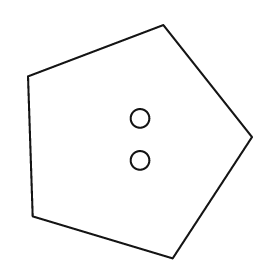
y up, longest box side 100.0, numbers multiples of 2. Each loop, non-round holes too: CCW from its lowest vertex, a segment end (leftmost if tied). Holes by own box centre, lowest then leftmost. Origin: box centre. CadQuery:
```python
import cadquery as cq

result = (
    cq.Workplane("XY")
    .moveTo(14.0, -50.0)
    .lineTo(48.0, 2.0)
    .lineTo(10.0, 50.0)
    .lineTo(-48.0, 28.0)
    .lineTo(-46.0, -32.0)
    .close()
    .moveTo(0.0, -8.0)
    .circle(4.0)
    .moveTo(0.0, 10.0)
    .circle(4.0)
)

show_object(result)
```